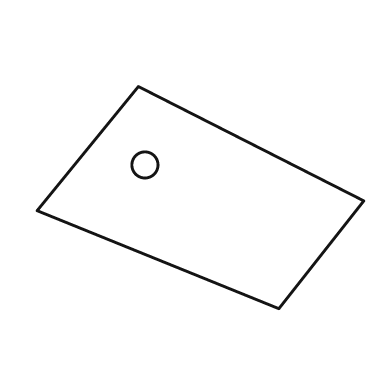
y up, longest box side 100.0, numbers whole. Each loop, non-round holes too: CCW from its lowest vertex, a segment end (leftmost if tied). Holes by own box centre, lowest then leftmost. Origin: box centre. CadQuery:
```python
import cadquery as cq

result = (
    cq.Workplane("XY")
    .moveTo(24.0, -34.0)
    .lineTo(50.0, -1.0)
    .lineTo(-19.0, 34.0)
    .lineTo(-50.0, -4.0)
    .close()
    .moveTo(-17.0, 10.0)
    .circle(4.0)
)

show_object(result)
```